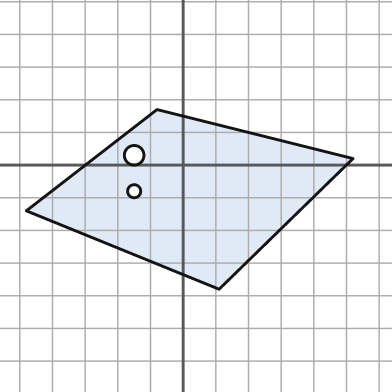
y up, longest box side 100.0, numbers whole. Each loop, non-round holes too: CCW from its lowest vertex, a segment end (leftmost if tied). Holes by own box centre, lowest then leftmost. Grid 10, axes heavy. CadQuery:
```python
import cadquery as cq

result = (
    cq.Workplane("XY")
    .moveTo(11.0, -38.0)
    .lineTo(52.0, 2.0)
    .lineTo(-8.0, 17.0)
    .lineTo(-48.0, -14.0)
    .close()
    .moveTo(-15.0, -8.0)
    .circle(2.0)
    .moveTo(-15.0, 3.0)
    .circle(3.0)
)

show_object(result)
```